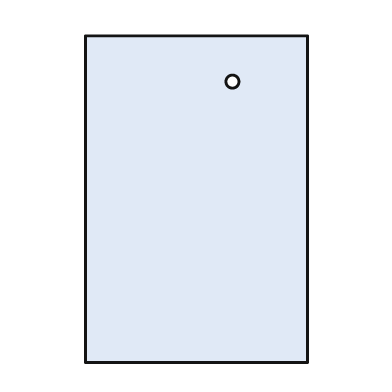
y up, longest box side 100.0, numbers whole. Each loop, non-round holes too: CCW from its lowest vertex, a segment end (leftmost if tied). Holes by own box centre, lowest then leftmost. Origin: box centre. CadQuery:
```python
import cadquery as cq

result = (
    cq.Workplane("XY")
    .moveTo(-34.0, -50.0)
    .lineTo(34.0, -50.0)
    .lineTo(34.0, 50.0)
    .lineTo(-34.0, 50.0)
    .close()
    .moveTo(11.0, 36.0)
    .circle(2.0)
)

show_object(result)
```